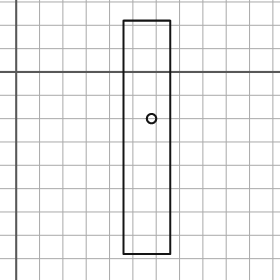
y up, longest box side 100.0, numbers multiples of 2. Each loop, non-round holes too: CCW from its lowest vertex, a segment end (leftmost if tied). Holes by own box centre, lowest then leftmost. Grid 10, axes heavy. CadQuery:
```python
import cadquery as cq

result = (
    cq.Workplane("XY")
    .moveTo(46.0, -78.0)
    .lineTo(66.0, -78.0)
    .lineTo(66.0, 22.0)
    .lineTo(46.0, 22.0)
    .close()
    .moveTo(58.0, -20.0)
    .circle(2.0)
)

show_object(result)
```